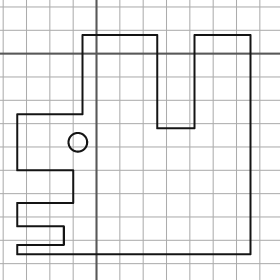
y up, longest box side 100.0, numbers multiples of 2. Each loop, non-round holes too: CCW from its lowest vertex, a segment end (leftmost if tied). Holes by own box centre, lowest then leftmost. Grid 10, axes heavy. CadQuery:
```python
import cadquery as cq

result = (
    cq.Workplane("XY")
    .moveTo(-34.0, -86.0)
    .lineTo(66.0, -86.0)
    .lineTo(66.0, 8.0)
    .lineTo(42.0, 8.0)
    .lineTo(42.0, -32.0)
    .lineTo(26.0, -32.0)
    .lineTo(26.0, 8.0)
    .lineTo(-6.0, 8.0)
    .lineTo(-6.0, -26.0)
    .lineTo(-34.0, -26.0)
    .lineTo(-34.0, -50.0)
    .lineTo(-10.0, -50.0)
    .lineTo(-10.0, -64.0)
    .lineTo(-34.0, -64.0)
    .lineTo(-34.0, -74.0)
    .lineTo(-14.0, -74.0)
    .lineTo(-14.0, -82.0)
    .lineTo(-34.0, -82.0)
    .close()
    .moveTo(-8.0, -38.0)
    .circle(4.0)
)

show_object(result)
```